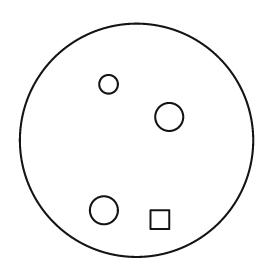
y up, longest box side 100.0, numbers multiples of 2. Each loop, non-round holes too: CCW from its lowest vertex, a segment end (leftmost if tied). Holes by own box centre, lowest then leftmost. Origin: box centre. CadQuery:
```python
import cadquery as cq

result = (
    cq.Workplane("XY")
    .moveTo(0.0, 0.0)
    .circle(50.0)
    .moveTo(6.0, -38.0)
    .lineTo(14.0, -38.0)
    .lineTo(14.0, -30.0)
    .lineTo(6.0, -30.0)
    .close()
    .moveTo(-14.0, -30.0)
    .circle(6.0)
    .moveTo(14.0, 10.0)
    .circle(6.0)
    .moveTo(-12.0, 24.0)
    .circle(4.0)
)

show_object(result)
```